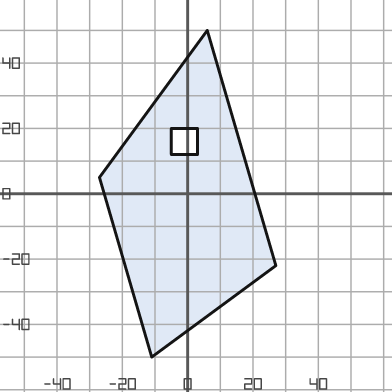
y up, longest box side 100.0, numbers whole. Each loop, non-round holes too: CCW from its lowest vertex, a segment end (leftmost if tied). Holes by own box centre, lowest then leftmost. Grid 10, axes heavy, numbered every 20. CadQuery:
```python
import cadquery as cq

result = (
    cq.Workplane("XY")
    .moveTo(-11.0, -50.0)
    .lineTo(27.0, -22.0)
    .lineTo(6.0, 50.0)
    .lineTo(-27.0, 5.0)
    .close()
    .moveTo(-5.0, 12.0)
    .lineTo(3.0, 12.0)
    .lineTo(3.0, 20.0)
    .lineTo(-5.0, 20.0)
    .close()
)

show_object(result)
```